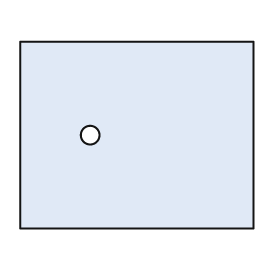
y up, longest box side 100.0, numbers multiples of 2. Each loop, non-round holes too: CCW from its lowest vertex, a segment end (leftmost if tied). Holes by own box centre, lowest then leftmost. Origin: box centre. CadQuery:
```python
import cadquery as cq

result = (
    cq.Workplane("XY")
    .moveTo(-50.0, -40.0)
    .lineTo(50.0, -40.0)
    .lineTo(50.0, 40.0)
    .lineTo(-50.0, 40.0)
    .close()
    .moveTo(-20.0, 0.0)
    .circle(4.0)
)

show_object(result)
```